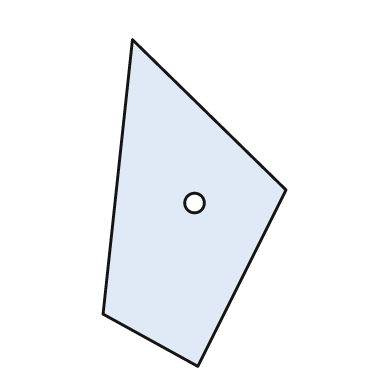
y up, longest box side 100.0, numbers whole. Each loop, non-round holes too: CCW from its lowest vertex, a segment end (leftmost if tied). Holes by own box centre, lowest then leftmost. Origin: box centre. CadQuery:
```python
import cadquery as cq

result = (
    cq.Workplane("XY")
    .moveTo(1.0, -50.0)
    .lineTo(28.0, 4.0)
    .lineTo(-19.0, 50.0)
    .lineTo(-28.0, -34.0)
    .close()
    .moveTo(0.0, 0.0)
    .circle(3.0)
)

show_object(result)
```